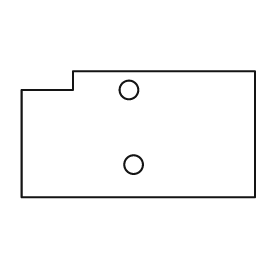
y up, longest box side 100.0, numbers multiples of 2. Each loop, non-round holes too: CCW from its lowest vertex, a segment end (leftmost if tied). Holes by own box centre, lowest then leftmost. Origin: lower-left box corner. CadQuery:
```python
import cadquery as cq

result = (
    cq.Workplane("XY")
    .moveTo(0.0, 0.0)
    .lineTo(100.0, 0.0)
    .lineTo(100.0, 54.0)
    .lineTo(22.0, 54.0)
    .lineTo(22.0, 46.0)
    .lineTo(0.0, 46.0)
    .close()
    .moveTo(48.0, 14.0)
    .circle(4.0)
    .moveTo(46.0, 46.0)
    .circle(4.0)
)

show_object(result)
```